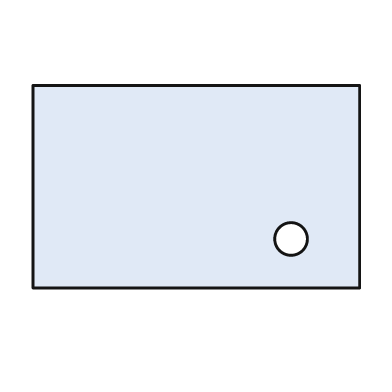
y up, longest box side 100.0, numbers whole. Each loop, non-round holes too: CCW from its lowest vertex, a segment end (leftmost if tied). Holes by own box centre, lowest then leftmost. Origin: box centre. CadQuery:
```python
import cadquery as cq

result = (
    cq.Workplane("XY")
    .moveTo(-50.0, -31.0)
    .lineTo(50.0, -31.0)
    .lineTo(50.0, 31.0)
    .lineTo(-50.0, 31.0)
    .close()
    .moveTo(29.0, -16.0)
    .circle(5.0)
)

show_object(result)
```